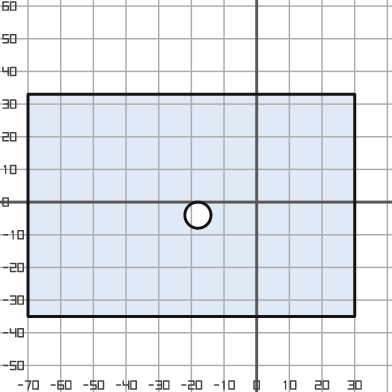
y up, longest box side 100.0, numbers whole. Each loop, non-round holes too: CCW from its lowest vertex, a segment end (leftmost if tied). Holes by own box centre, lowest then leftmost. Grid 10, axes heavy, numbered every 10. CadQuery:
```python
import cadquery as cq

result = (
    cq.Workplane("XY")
    .moveTo(-70.0, -35.0)
    .lineTo(30.0, -35.0)
    .lineTo(30.0, 33.0)
    .lineTo(-70.0, 33.0)
    .close()
    .moveTo(-18.0, -4.0)
    .circle(4.0)
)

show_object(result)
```